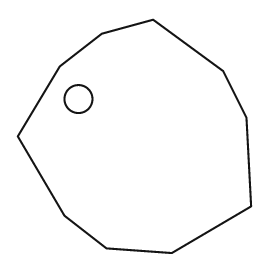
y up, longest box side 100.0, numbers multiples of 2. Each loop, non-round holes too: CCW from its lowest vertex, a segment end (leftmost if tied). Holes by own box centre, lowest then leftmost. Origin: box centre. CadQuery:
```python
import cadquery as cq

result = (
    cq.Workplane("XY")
    .moveTo(16.0, -50.0)
    .lineTo(50.0, -30.0)
    .lineTo(48.0, 8.0)
    .lineTo(38.0, 28.0)
    .lineTo(8.0, 50.0)
    .lineTo(-14.0, 44.0)
    .lineTo(-32.0, 30.0)
    .lineTo(-50.0, 0.0)
    .lineTo(-30.0, -34.0)
    .lineTo(-12.0, -48.0)
    .close()
    .moveTo(-24.0, 16.0)
    .circle(6.0)
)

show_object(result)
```